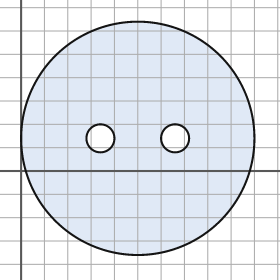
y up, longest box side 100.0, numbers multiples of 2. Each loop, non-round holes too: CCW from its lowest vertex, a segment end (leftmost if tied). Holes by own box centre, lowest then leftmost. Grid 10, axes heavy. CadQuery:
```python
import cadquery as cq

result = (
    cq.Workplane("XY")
    .moveTo(50.0, 14.0)
    .circle(50.0)
    .moveTo(34.0, 14.0)
    .circle(6.0)
    .moveTo(66.0, 14.0)
    .circle(6.0)
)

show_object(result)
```